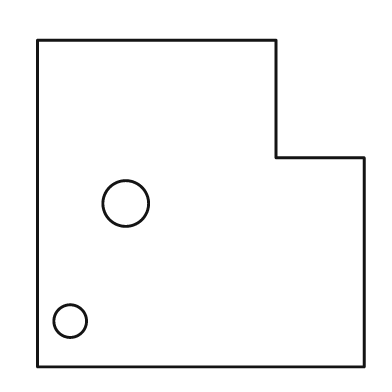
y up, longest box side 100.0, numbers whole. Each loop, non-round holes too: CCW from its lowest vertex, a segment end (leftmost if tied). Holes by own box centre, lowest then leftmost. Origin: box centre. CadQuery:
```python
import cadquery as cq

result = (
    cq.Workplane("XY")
    .moveTo(-50.0, -50.0)
    .lineTo(50.0, -50.0)
    .lineTo(50.0, 14.0)
    .lineTo(23.0, 14.0)
    .lineTo(23.0, 50.0)
    .lineTo(-50.0, 50.0)
    .close()
    .moveTo(-40.0, -36.0)
    .circle(5.0)
    .moveTo(-23.0, 0.0)
    .circle(7.0)
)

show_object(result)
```